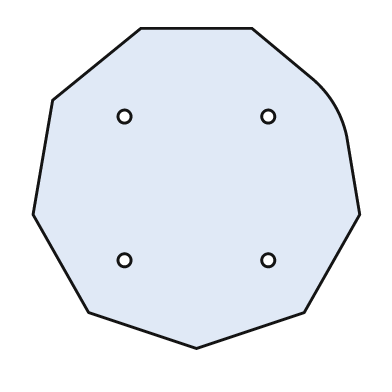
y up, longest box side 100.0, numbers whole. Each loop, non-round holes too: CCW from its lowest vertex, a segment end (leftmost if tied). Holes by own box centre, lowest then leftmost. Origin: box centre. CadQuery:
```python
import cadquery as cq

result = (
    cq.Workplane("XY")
    .moveTo(0.0, -49.0)
    .lineTo(33.0, -38.0)
    .lineTo(50.0, -8.0)
    .lineTo(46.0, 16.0)
    .threePointArc((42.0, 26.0), (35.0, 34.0))
    .lineTo(17.0, 49.0)
    .lineTo(-17.0, 49.0)
    .lineTo(-44.0, 27.0)
    .lineTo(-50.0, -8.0)
    .lineTo(-33.0, -38.0)
    .close()
    .moveTo(-22.0, -22.0)
    .circle(2.0)
    .moveTo(22.0, -22.0)
    .circle(2.0)
    .moveTo(-22.0, 22.0)
    .circle(2.0)
    .moveTo(22.0, 22.0)
    .circle(2.0)
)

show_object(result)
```